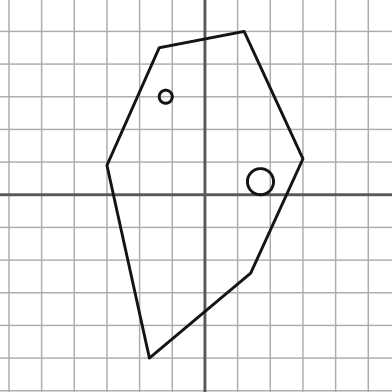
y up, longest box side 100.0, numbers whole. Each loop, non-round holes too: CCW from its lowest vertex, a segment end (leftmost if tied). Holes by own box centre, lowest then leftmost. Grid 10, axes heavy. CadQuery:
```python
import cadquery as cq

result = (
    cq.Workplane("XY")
    .moveTo(-17.0, -50.0)
    .lineTo(14.0, -24.0)
    .lineTo(30.0, 11.0)
    .lineTo(12.0, 50.0)
    .lineTo(-14.0, 45.0)
    .lineTo(-30.0, 9.0)
    .close()
    .moveTo(17.0, 4.0)
    .circle(4.0)
    .moveTo(-12.0, 30.0)
    .circle(2.0)
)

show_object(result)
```